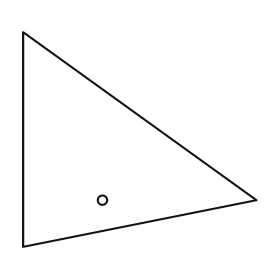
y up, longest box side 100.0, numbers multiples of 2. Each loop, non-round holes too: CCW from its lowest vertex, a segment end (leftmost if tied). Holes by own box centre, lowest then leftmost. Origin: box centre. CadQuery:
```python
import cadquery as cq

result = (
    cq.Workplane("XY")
    .moveTo(-50.0, -46.0)
    .lineTo(50.0, -26.0)
    .lineTo(-50.0, 46.0)
    .close()
    .moveTo(-16.0, -26.0)
    .circle(2.0)
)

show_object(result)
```